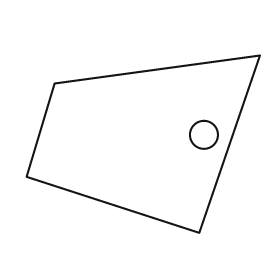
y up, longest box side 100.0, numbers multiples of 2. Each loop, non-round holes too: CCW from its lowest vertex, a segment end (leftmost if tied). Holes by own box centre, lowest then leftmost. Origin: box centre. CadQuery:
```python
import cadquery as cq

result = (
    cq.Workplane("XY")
    .moveTo(24.0, -38.0)
    .lineTo(50.0, 38.0)
    .lineTo(-38.0, 26.0)
    .lineTo(-50.0, -14.0)
    .close()
    .moveTo(26.0, 4.0)
    .circle(6.0)
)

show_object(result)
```